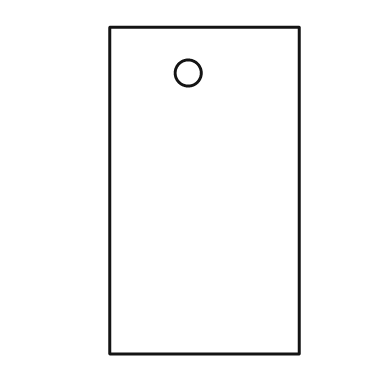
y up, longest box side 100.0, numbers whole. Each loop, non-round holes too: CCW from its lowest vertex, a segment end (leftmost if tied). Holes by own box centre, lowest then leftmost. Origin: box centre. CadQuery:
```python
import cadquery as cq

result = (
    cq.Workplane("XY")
    .moveTo(-29.0, -50.0)
    .lineTo(29.0, -50.0)
    .lineTo(29.0, 50.0)
    .lineTo(-29.0, 50.0)
    .close()
    .moveTo(-5.0, 36.0)
    .circle(4.0)
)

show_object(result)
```